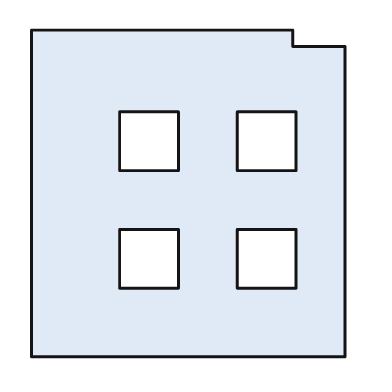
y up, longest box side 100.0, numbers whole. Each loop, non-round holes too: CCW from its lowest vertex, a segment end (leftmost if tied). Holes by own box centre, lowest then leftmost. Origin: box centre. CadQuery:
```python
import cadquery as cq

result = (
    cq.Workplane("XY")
    .moveTo(-48.0, -50.0)
    .lineTo(48.0, -50.0)
    .lineTo(48.0, 45.0)
    .lineTo(32.0, 45.0)
    .lineTo(32.0, 50.0)
    .lineTo(-48.0, 50.0)
    .close()
    .moveTo(-21.0, -29.0)
    .lineTo(-3.0, -29.0)
    .lineTo(-3.0, -11.0)
    .lineTo(-21.0, -11.0)
    .close()
    .moveTo(15.0, -29.0)
    .lineTo(33.0, -29.0)
    .lineTo(33.0, -11.0)
    .lineTo(15.0, -11.0)
    .close()
    .moveTo(-21.0, 7.0)
    .lineTo(-3.0, 7.0)
    .lineTo(-3.0, 25.0)
    .lineTo(-21.0, 25.0)
    .close()
    .moveTo(15.0, 7.0)
    .lineTo(33.0, 7.0)
    .lineTo(33.0, 25.0)
    .lineTo(15.0, 25.0)
    .close()
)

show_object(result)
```